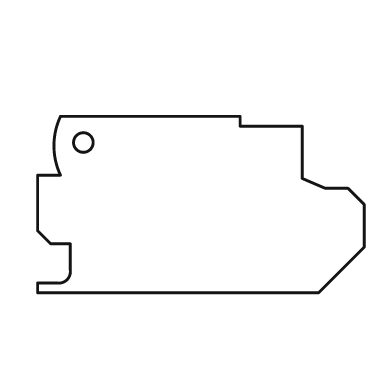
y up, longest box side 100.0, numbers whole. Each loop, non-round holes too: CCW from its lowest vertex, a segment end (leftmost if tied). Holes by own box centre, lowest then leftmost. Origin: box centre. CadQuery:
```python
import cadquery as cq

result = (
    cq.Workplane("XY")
    .moveTo(-50.0, -27.0)
    .lineTo(36.0, -27.0)
    .lineTo(50.0, -13.0)
    .lineTo(50.0, 0.0)
    .lineTo(45.0, 5.0)
    .lineTo(38.0, 5.0)
    .lineTo(31.0, 8.0)
    .lineTo(31.0, 24.0)
    .lineTo(12.0, 24.0)
    .lineTo(12.0, 27.0)
    .lineTo(-43.0, 27.0)
    .threePointArc((-45.0, 18.0), (-43.0, 9.0))
    .lineTo(-50.0, 9.0)
    .lineTo(-50.0, -8.0)
    .lineTo(-46.0, -12.0)
    .lineTo(-40.0, -12.0)
    .lineTo(-40.0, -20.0)
    .threePointArc((-41.0, -23.0), (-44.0, -24.0))
    .lineTo(-50.0, -24.0)
    .close()
    .moveTo(-36.0, 19.0)
    .circle(3.0)
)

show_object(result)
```